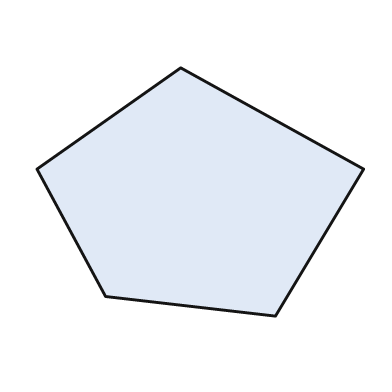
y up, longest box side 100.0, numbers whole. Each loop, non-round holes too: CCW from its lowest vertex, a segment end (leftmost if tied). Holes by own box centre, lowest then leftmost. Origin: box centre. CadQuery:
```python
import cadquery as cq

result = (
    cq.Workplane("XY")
    .moveTo(23.0, -38.0)
    .lineTo(50.0, 7.0)
    .lineTo(-6.0, 38.0)
    .lineTo(-50.0, 7.0)
    .lineTo(-29.0, -32.0)
    .close()
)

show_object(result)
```